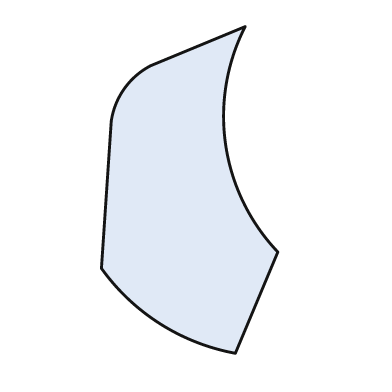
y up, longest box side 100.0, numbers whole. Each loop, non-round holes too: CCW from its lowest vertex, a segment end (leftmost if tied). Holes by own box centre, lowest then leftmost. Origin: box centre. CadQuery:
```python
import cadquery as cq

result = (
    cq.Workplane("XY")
    .moveTo(14.0, -50.0)
    .lineTo(27.0, -19.0)
    .threePointArc((11.0, 14.0), (17.0, 50.0))
    .lineTo(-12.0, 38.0)
    .threePointArc((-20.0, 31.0), (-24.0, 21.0))
    .lineTo(-27.0, -24.0)
    .threePointArc((-9.0, -41.0), (14.0, -50.0))
    .close()
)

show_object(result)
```